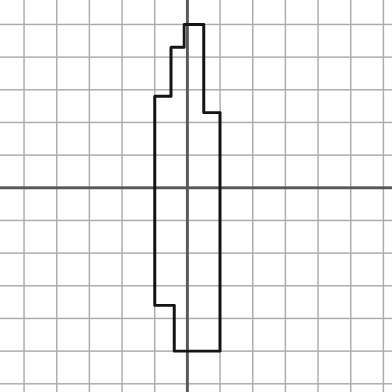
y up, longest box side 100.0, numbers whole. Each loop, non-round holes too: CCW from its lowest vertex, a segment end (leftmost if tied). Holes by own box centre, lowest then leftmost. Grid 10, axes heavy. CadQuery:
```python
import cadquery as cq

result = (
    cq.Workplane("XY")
    .moveTo(-4.0, -50.0)
    .lineTo(10.0, -50.0)
    .lineTo(10.0, 23.0)
    .lineTo(5.0, 23.0)
    .lineTo(5.0, 50.0)
    .lineTo(-1.0, 50.0)
    .lineTo(-1.0, 43.0)
    .lineTo(-5.0, 43.0)
    .lineTo(-5.0, 28.0)
    .lineTo(-10.0, 28.0)
    .lineTo(-10.0, -36.0)
    .lineTo(-4.0, -36.0)
    .close()
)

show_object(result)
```